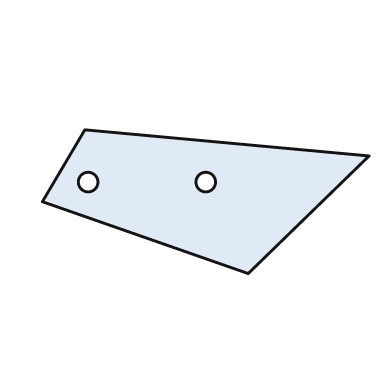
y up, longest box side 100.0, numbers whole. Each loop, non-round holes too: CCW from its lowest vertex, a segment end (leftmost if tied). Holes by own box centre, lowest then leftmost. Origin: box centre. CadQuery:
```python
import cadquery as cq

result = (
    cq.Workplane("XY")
    .moveTo(13.0, -22.0)
    .lineTo(50.0, 14.0)
    .lineTo(-37.0, 22.0)
    .lineTo(-50.0, 0.0)
    .close()
    .moveTo(-36.0, 6.0)
    .circle(3.0)
    .moveTo(0.0, 6.0)
    .circle(3.0)
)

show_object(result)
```